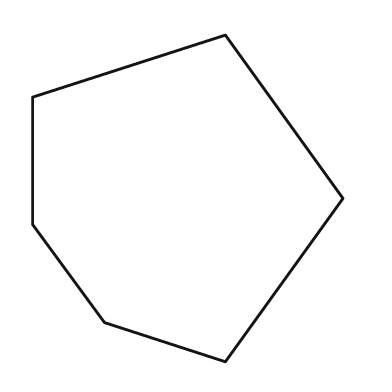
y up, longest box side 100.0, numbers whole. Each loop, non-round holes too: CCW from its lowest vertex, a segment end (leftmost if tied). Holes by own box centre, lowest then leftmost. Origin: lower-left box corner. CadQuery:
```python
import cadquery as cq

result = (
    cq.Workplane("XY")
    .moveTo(59.0, 0.0)
    .lineTo(95.0, 50.0)
    .lineTo(59.0, 100.0)
    .lineTo(0.0, 81.0)
    .lineTo(0.0, 42.0)
    .lineTo(22.0, 12.0)
    .close()
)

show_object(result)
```